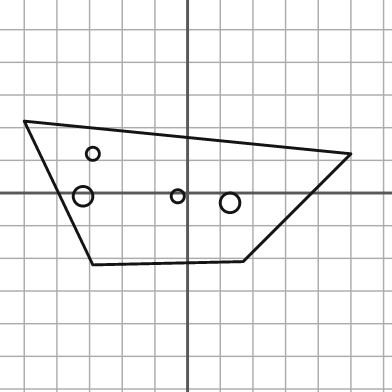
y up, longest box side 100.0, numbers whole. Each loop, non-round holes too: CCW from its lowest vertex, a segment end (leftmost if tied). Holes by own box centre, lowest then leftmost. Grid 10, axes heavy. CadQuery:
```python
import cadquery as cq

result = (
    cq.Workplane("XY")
    .moveTo(-29.0, -22.0)
    .lineTo(17.0, -21.0)
    .lineTo(50.0, 12.0)
    .lineTo(-50.0, 22.0)
    .close()
    .moveTo(13.0, -3.0)
    .circle(3.0)
    .moveTo(-32.0, -1.0)
    .circle(3.0)
    .moveTo(-3.0, -1.0)
    .circle(2.0)
    .moveTo(-29.0, 12.0)
    .circle(2.0)
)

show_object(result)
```